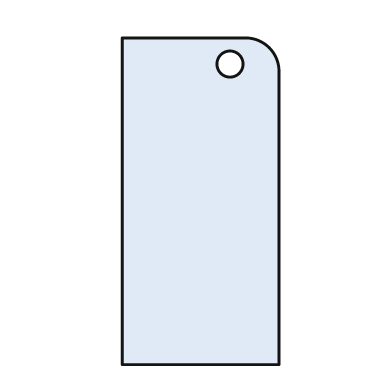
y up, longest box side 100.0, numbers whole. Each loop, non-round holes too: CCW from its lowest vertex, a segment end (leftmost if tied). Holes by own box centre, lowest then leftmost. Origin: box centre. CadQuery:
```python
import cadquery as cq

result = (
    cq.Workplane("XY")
    .moveTo(-24.0, -50.0)
    .lineTo(24.0, -50.0)
    .lineTo(24.0, 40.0)
    .threePointArc((21.0, 47.0), (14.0, 50.0))
    .lineTo(-24.0, 50.0)
    .close()
    .moveTo(9.0, 42.0)
    .circle(4.0)
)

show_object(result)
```